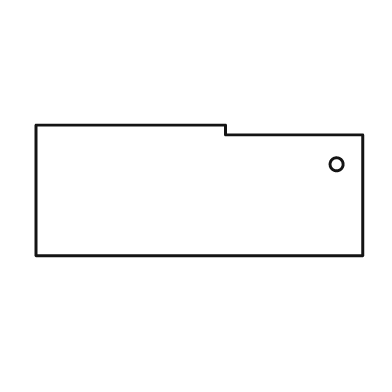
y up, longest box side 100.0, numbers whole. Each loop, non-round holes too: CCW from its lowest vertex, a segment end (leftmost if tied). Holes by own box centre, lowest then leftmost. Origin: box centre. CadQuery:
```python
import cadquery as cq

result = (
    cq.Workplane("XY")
    .moveTo(-50.0, -20.0)
    .lineTo(50.0, -20.0)
    .lineTo(50.0, 17.0)
    .lineTo(8.0, 17.0)
    .lineTo(8.0, 20.0)
    .lineTo(-50.0, 20.0)
    .close()
    .moveTo(42.0, 8.0)
    .circle(2.0)
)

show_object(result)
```